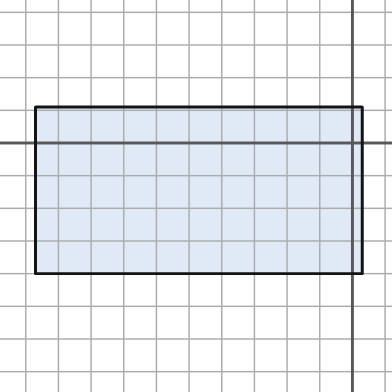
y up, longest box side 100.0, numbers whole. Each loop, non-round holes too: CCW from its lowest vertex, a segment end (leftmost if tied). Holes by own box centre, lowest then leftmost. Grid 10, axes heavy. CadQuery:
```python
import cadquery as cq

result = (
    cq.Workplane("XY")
    .moveTo(-97.0, -40.0)
    .lineTo(3.0, -40.0)
    .lineTo(3.0, 11.0)
    .lineTo(-97.0, 11.0)
    .close()
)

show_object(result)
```